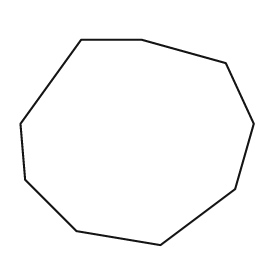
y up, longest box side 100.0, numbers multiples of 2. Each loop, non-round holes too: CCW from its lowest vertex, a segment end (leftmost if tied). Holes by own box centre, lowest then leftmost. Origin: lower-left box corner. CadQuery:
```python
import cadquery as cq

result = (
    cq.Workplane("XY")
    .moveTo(60.0, 0.0)
    .lineTo(92.0, 24.0)
    .lineTo(100.0, 52.0)
    .lineTo(88.0, 78.0)
    .lineTo(52.0, 88.0)
    .lineTo(26.0, 88.0)
    .lineTo(0.0, 52.0)
    .lineTo(2.0, 28.0)
    .lineTo(24.0, 6.0)
    .close()
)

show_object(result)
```